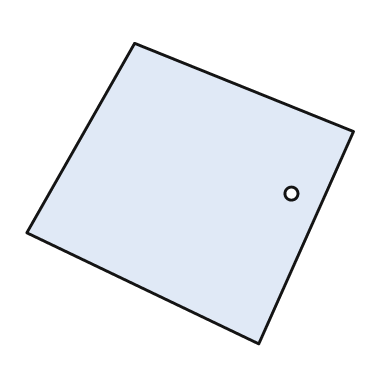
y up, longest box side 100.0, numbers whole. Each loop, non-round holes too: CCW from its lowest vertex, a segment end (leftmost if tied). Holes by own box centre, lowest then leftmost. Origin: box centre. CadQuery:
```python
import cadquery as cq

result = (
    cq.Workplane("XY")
    .moveTo(21.0, -46.0)
    .lineTo(50.0, 19.0)
    .lineTo(-17.0, 46.0)
    .lineTo(-50.0, -12.0)
    .close()
    .moveTo(31.0, 0.0)
    .circle(2.0)
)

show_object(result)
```